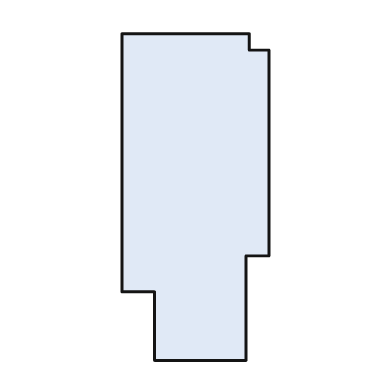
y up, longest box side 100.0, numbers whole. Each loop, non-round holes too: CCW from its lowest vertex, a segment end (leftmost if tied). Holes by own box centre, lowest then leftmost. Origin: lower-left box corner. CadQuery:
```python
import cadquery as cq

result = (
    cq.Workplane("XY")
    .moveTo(10.0, 0.0)
    .lineTo(38.0, 0.0)
    .lineTo(38.0, 32.0)
    .lineTo(45.0, 32.0)
    .lineTo(45.0, 95.0)
    .lineTo(39.0, 95.0)
    .lineTo(39.0, 100.0)
    .lineTo(0.0, 100.0)
    .lineTo(0.0, 21.0)
    .lineTo(10.0, 21.0)
    .close()
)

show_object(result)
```